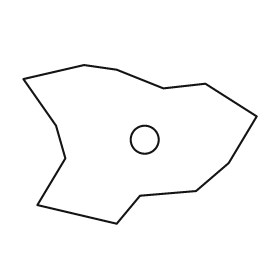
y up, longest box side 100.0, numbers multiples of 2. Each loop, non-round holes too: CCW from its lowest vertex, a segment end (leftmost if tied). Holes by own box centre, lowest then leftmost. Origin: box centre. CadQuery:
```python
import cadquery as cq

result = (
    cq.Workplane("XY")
    .moveTo(-10.0, -34.0)
    .lineTo(0.0, -22.0)
    .lineTo(24.0, -20.0)
    .lineTo(38.0, -8.0)
    .lineTo(50.0, 12.0)
    .lineTo(28.0, 26.0)
    .lineTo(10.0, 24.0)
    .lineTo(-10.0, 32.0)
    .lineTo(-24.0, 34.0)
    .lineTo(-50.0, 28.0)
    .lineTo(-36.0, 8.0)
    .lineTo(-32.0, -6.0)
    .lineTo(-44.0, -26.0)
    .close()
    .moveTo(2.0, 2.0)
    .circle(6.0)
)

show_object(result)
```